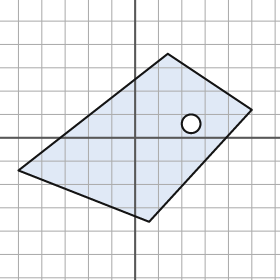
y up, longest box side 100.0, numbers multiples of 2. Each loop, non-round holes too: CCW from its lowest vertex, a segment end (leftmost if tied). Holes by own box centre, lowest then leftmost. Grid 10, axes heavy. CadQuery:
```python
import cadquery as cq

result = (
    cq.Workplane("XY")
    .moveTo(6.0, -36.0)
    .lineTo(50.0, 12.0)
    .lineTo(14.0, 36.0)
    .lineTo(-50.0, -14.0)
    .close()
    .moveTo(24.0, 6.0)
    .circle(4.0)
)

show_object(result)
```